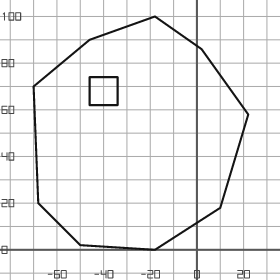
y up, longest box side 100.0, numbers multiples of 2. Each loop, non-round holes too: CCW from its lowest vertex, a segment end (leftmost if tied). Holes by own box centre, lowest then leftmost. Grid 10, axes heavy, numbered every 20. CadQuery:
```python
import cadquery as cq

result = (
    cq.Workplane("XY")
    .moveTo(-18.0, 0.0)
    .lineTo(10.0, 18.0)
    .lineTo(22.0, 58.0)
    .lineTo(2.0, 86.0)
    .lineTo(-18.0, 100.0)
    .lineTo(-46.0, 90.0)
    .lineTo(-70.0, 70.0)
    .lineTo(-68.0, 20.0)
    .lineTo(-50.0, 2.0)
    .close()
    .moveTo(-46.0, 62.0)
    .lineTo(-34.0, 62.0)
    .lineTo(-34.0, 74.0)
    .lineTo(-46.0, 74.0)
    .close()
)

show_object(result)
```